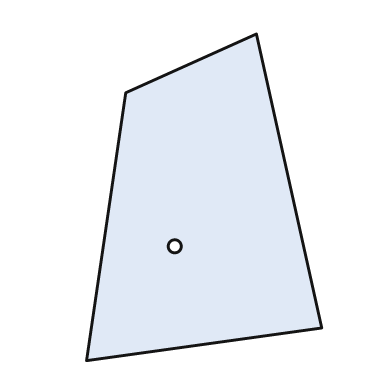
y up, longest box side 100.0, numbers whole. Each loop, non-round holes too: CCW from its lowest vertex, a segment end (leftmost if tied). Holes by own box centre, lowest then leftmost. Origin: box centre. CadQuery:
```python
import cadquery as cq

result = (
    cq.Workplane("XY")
    .moveTo(-36.0, -50.0)
    .lineTo(36.0, -40.0)
    .lineTo(16.0, 50.0)
    .lineTo(-24.0, 32.0)
    .close()
    .moveTo(-9.0, -15.0)
    .circle(2.0)
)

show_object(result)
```